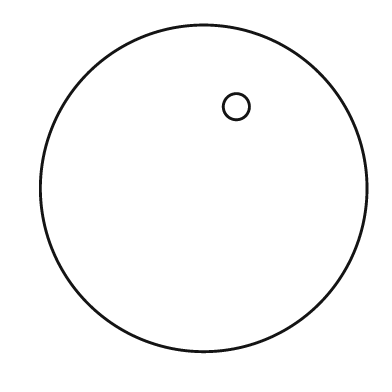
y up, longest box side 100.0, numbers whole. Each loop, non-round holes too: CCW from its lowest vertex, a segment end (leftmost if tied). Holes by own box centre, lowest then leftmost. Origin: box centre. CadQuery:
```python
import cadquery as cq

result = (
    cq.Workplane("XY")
    .moveTo(0.0, 0.0)
    .circle(50.0)
    .moveTo(10.0, 25.0)
    .circle(4.0)
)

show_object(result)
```